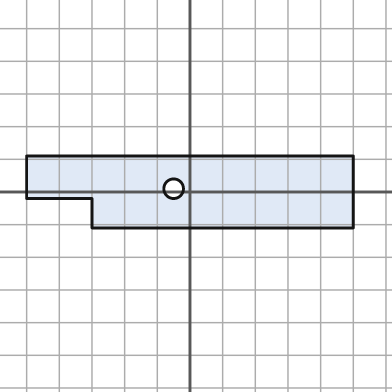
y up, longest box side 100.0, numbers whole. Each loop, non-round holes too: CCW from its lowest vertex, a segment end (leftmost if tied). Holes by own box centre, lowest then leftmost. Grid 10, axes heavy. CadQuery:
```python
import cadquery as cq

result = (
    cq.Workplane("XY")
    .moveTo(-30.0, -11.0)
    .lineTo(50.0, -11.0)
    .lineTo(50.0, 11.0)
    .lineTo(-50.0, 11.0)
    .lineTo(-50.0, -2.0)
    .lineTo(-30.0, -2.0)
    .close()
    .moveTo(-5.0, 1.0)
    .circle(3.0)
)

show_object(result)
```